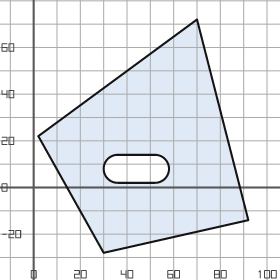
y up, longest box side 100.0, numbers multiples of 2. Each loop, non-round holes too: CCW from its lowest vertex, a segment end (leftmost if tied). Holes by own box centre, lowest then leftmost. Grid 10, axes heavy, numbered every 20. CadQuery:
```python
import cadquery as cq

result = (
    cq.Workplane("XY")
    .moveTo(30.0, -28.0)
    .lineTo(92.0, -14.0)
    .lineTo(70.0, 72.0)
    .lineTo(2.0, 22.0)
    .close()
    .moveTo(36.0, 2.0)
    .lineTo(52.0, 2.0)
    .threePointArc((58.0, 8.0), (52.0, 14.0))
    .lineTo(36.0, 14.0)
    .threePointArc((30.0, 8.0), (36.0, 2.0))
    .close()
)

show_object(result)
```